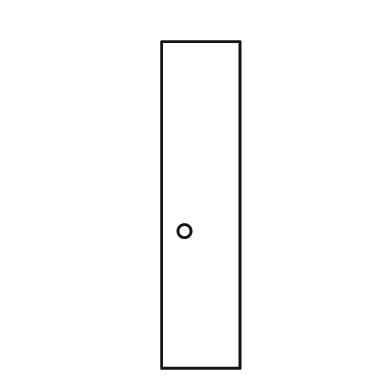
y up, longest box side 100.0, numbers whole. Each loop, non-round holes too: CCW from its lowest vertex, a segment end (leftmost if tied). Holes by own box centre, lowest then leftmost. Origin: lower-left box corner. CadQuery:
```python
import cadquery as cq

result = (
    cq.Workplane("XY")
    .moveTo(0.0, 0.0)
    .lineTo(24.0, 0.0)
    .lineTo(24.0, 100.0)
    .lineTo(0.0, 100.0)
    .close()
    .moveTo(7.0, 42.0)
    .circle(2.0)
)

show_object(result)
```